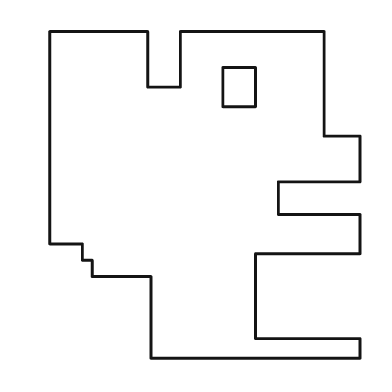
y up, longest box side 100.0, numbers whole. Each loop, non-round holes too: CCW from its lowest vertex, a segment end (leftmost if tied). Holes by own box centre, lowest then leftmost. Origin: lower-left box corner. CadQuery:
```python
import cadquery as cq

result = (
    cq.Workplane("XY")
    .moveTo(31.0, 0.0)
    .lineTo(95.0, 0.0)
    .lineTo(95.0, 6.0)
    .lineTo(63.0, 6.0)
    .lineTo(63.0, 32.0)
    .lineTo(95.0, 32.0)
    .lineTo(95.0, 44.0)
    .lineTo(70.0, 44.0)
    .lineTo(70.0, 54.0)
    .lineTo(95.0, 54.0)
    .lineTo(95.0, 68.0)
    .lineTo(84.0, 68.0)
    .lineTo(84.0, 100.0)
    .lineTo(40.0, 100.0)
    .lineTo(40.0, 83.0)
    .lineTo(30.0, 83.0)
    .lineTo(30.0, 100.0)
    .lineTo(0.0, 100.0)
    .lineTo(0.0, 35.0)
    .lineTo(10.0, 35.0)
    .lineTo(10.0, 30.0)
    .lineTo(13.0, 30.0)
    .lineTo(13.0, 25.0)
    .lineTo(31.0, 25.0)
    .close()
    .moveTo(53.0, 77.0)
    .lineTo(63.0, 77.0)
    .lineTo(63.0, 89.0)
    .lineTo(53.0, 89.0)
    .close()
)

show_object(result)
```